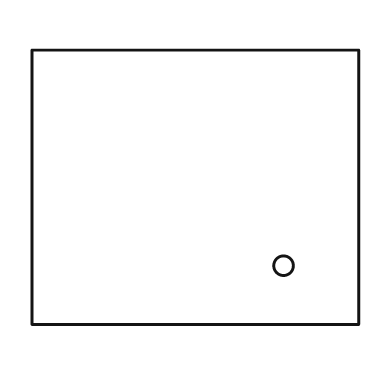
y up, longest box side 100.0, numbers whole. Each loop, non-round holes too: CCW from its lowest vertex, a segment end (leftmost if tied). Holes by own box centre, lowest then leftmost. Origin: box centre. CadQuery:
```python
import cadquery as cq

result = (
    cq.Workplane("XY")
    .moveTo(-50.0, -42.0)
    .lineTo(50.0, -42.0)
    .lineTo(50.0, 42.0)
    .lineTo(-50.0, 42.0)
    .close()
    .moveTo(27.0, -24.0)
    .circle(3.0)
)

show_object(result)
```